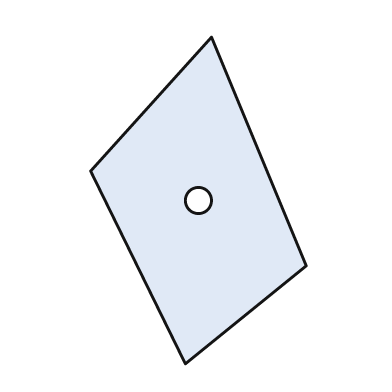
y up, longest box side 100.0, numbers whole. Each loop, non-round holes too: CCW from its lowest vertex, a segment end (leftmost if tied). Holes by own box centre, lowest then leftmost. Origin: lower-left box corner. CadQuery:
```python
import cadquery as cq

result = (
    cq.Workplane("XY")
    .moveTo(29.0, 0.0)
    .lineTo(66.0, 30.0)
    .lineTo(37.0, 100.0)
    .lineTo(0.0, 59.0)
    .close()
    .moveTo(33.0, 50.0)
    .circle(4.0)
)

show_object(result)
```